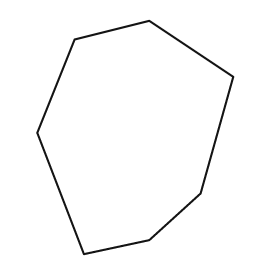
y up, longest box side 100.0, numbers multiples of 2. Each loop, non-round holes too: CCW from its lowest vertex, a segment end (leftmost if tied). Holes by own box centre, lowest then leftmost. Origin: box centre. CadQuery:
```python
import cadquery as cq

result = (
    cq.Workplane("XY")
    .moveTo(-22.0, -50.0)
    .lineTo(6.0, -44.0)
    .lineTo(28.0, -24.0)
    .lineTo(42.0, 26.0)
    .lineTo(6.0, 50.0)
    .lineTo(-26.0, 42.0)
    .lineTo(-42.0, 2.0)
    .close()
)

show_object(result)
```